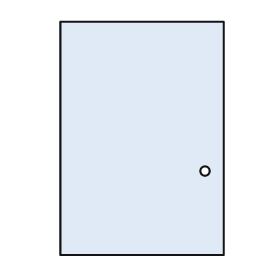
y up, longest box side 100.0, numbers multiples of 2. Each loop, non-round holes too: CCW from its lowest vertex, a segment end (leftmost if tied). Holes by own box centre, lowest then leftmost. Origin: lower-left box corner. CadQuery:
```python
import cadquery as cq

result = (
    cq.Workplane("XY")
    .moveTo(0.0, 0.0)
    .lineTo(70.0, 0.0)
    .lineTo(70.0, 100.0)
    .lineTo(0.0, 100.0)
    .close()
    .moveTo(62.0, 36.0)
    .circle(2.0)
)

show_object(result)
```